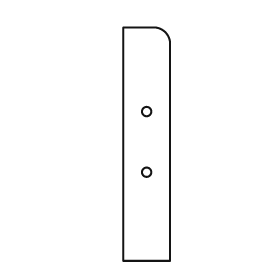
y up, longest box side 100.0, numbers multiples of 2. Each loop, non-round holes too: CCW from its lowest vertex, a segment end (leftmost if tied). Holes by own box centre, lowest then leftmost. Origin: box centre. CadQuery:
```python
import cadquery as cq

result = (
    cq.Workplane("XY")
    .moveTo(-10.0, -50.0)
    .lineTo(10.0, -50.0)
    .lineTo(10.0, 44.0)
    .threePointArc((8.0, 48.0), (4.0, 50.0))
    .lineTo(-10.0, 50.0)
    .close()
    .moveTo(0.0, -12.0)
    .circle(2.0)
    .moveTo(0.0, 14.0)
    .circle(2.0)
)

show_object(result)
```